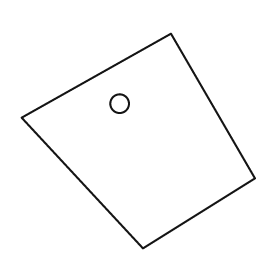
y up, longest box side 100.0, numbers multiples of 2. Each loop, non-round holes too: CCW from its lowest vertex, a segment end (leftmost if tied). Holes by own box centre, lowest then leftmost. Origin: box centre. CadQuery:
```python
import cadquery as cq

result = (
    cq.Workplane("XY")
    .moveTo(2.0, -46.0)
    .lineTo(50.0, -16.0)
    .lineTo(14.0, 46.0)
    .lineTo(-50.0, 10.0)
    .close()
    .moveTo(-8.0, 16.0)
    .circle(4.0)
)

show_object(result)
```